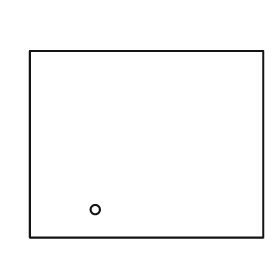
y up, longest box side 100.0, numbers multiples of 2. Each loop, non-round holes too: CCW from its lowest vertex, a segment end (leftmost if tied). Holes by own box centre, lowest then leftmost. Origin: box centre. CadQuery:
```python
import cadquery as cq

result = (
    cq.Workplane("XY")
    .moveTo(-50.0, -40.0)
    .lineTo(50.0, -40.0)
    .lineTo(50.0, 40.0)
    .lineTo(-50.0, 40.0)
    .close()
    .moveTo(-22.0, -28.0)
    .circle(2.0)
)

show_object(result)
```